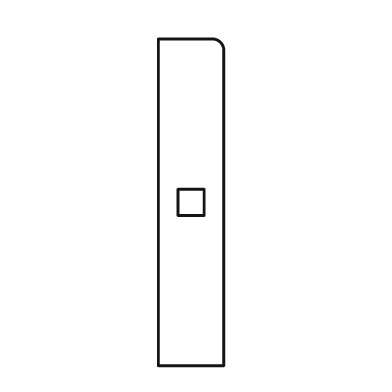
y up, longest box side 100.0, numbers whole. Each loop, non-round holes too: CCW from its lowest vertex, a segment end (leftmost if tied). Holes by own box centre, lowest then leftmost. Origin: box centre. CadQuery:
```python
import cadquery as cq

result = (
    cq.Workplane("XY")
    .moveTo(-10.0, -50.0)
    .lineTo(10.0, -50.0)
    .lineTo(10.0, 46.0)
    .threePointArc((9.0, 49.0), (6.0, 50.0))
    .lineTo(-10.0, 50.0)
    .close()
    .moveTo(-4.0, -4.0)
    .lineTo(4.0, -4.0)
    .lineTo(4.0, 4.0)
    .lineTo(-4.0, 4.0)
    .close()
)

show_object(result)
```